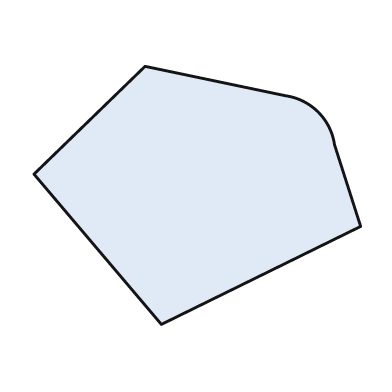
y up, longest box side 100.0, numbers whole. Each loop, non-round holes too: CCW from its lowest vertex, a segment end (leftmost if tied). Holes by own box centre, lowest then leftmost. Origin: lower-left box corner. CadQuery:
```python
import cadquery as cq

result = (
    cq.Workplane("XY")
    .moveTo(39.0, 0.0)
    .lineTo(100.0, 30.0)
    .lineTo(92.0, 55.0)
    .threePointArc((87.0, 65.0), (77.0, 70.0))
    .lineTo(34.0, 79.0)
    .lineTo(0.0, 46.0)
    .close()
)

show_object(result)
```